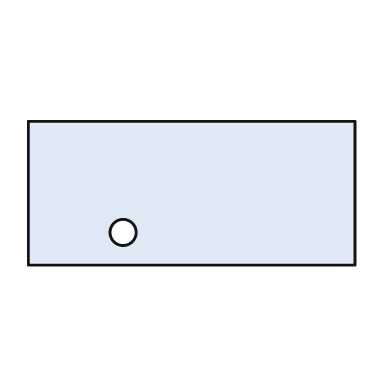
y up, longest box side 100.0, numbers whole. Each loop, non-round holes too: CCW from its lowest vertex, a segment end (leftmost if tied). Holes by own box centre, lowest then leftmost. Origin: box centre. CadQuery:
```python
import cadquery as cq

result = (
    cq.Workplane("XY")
    .moveTo(-50.0, -22.0)
    .lineTo(50.0, -22.0)
    .lineTo(50.0, 22.0)
    .lineTo(-50.0, 22.0)
    .close()
    .moveTo(-21.0, -12.0)
    .circle(4.0)
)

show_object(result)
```